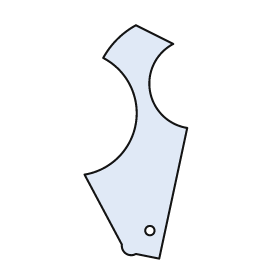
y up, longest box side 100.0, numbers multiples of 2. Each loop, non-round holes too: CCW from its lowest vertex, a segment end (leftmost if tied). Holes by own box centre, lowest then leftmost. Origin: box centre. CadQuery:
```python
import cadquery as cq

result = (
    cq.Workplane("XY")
    .moveTo(10.0, -50.0)
    .lineTo(22.0, 6.0)
    .threePointArc((6.0, 22.0), (16.0, 42.0))
    .lineTo(0.0, 50.0)
    .threePointArc((-8.0, 44.0), (-14.0, 36.0))
    .threePointArc((0.0, 8.0), (-22.0, -14.0))
    .lineTo(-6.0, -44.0)
    .threePointArc((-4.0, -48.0), (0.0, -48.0))
    .close()
    .moveTo(6.0, -38.0)
    .circle(2.0)
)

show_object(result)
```